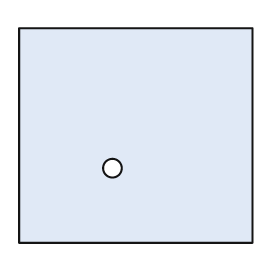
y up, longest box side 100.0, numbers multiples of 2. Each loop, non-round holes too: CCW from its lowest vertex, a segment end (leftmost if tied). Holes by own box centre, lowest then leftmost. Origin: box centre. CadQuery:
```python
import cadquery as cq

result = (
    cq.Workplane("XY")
    .moveTo(-50.0, -46.0)
    .lineTo(50.0, -46.0)
    .lineTo(50.0, 46.0)
    .lineTo(-50.0, 46.0)
    .close()
    .moveTo(-10.0, -14.0)
    .circle(4.0)
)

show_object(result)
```